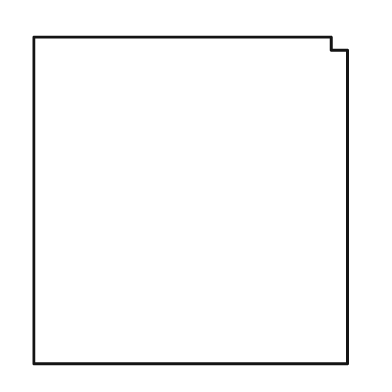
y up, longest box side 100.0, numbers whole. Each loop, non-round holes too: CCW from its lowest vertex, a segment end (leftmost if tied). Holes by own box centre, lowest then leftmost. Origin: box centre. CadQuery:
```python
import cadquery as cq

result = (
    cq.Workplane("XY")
    .moveTo(-48.0, -50.0)
    .lineTo(48.0, -50.0)
    .lineTo(48.0, 46.0)
    .lineTo(43.0, 46.0)
    .lineTo(43.0, 50.0)
    .lineTo(-48.0, 50.0)
    .close()
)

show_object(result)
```